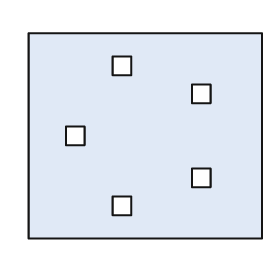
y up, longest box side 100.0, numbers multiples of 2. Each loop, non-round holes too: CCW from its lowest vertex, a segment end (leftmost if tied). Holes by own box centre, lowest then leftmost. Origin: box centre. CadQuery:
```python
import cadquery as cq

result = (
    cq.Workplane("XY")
    .moveTo(-50.0, -44.0)
    .lineTo(50.0, -44.0)
    .lineTo(50.0, 44.0)
    .lineTo(-50.0, 44.0)
    .close()
    .moveTo(-14.0, -34.0)
    .lineTo(-6.0, -34.0)
    .lineTo(-6.0, -26.0)
    .lineTo(-14.0, -26.0)
    .close()
    .moveTo(20.0, -22.0)
    .lineTo(28.0, -22.0)
    .lineTo(28.0, -14.0)
    .lineTo(20.0, -14.0)
    .close()
    .moveTo(-34.0, -4.0)
    .lineTo(-26.0, -4.0)
    .lineTo(-26.0, 4.0)
    .lineTo(-34.0, 4.0)
    .close()
    .moveTo(20.0, 14.0)
    .lineTo(28.0, 14.0)
    .lineTo(28.0, 22.0)
    .lineTo(20.0, 22.0)
    .close()
    .moveTo(-14.0, 26.0)
    .lineTo(-6.0, 26.0)
    .lineTo(-6.0, 34.0)
    .lineTo(-14.0, 34.0)
    .close()
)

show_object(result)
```